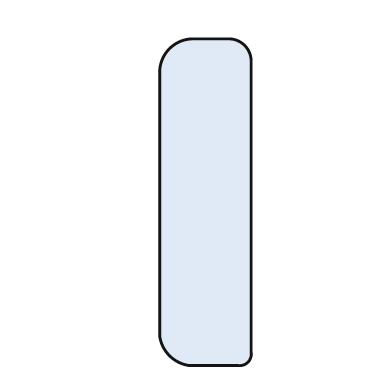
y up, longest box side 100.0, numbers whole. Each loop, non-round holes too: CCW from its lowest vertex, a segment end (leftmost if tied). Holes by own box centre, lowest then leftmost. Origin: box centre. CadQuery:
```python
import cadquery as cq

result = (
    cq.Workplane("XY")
    .moveTo(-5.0, -50.0)
    .lineTo(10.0, -50.0)
    .threePointArc((13.0, -49.0), (14.0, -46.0))
    .lineTo(14.0, 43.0)
    .threePointArc((12.0, 48.0), (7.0, 50.0))
    .lineTo(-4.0, 50.0)
    .threePointArc((-11.0, 47.0), (-14.0, 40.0))
    .lineTo(-14.0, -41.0)
    .threePointArc((-11.0, -47.0), (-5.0, -50.0))
    .close()
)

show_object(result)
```